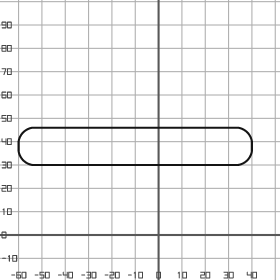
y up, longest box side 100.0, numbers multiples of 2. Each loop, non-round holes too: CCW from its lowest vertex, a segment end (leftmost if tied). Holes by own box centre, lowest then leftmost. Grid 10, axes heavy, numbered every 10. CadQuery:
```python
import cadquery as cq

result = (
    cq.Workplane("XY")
    .moveTo(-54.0, 30.0)
    .lineTo(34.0, 30.0)
    .threePointArc((38.0, 32.0), (40.0, 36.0))
    .lineTo(40.0, 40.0)
    .threePointArc((38.0, 44.0), (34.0, 46.0))
    .lineTo(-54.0, 46.0)
    .threePointArc((-58.0, 44.0), (-60.0, 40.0))
    .lineTo(-60.0, 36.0)
    .threePointArc((-58.0, 32.0), (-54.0, 30.0))
    .close()
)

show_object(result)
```